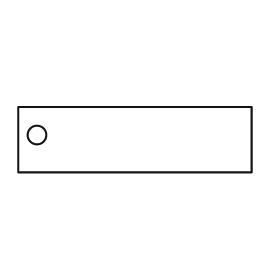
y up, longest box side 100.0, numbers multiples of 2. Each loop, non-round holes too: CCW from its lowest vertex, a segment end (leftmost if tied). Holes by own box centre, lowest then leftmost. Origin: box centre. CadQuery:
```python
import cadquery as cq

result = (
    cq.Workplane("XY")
    .moveTo(-50.0, -14.0)
    .lineTo(50.0, -14.0)
    .lineTo(50.0, 14.0)
    .lineTo(-50.0, 14.0)
    .close()
    .moveTo(-42.0, 2.0)
    .circle(4.0)
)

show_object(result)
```